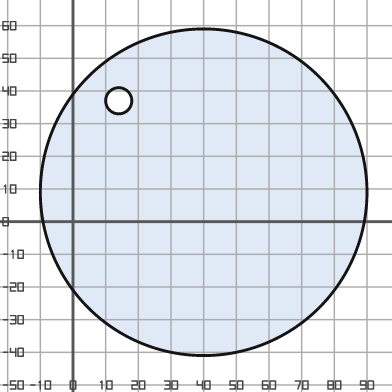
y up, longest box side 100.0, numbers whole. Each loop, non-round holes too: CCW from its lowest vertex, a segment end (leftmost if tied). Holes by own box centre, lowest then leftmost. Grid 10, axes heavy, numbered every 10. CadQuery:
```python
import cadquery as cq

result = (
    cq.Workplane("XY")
    .moveTo(40.0, 9.0)
    .circle(50.0)
    .moveTo(14.0, 37.0)
    .circle(4.0)
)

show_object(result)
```